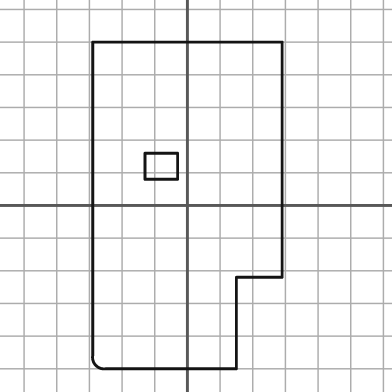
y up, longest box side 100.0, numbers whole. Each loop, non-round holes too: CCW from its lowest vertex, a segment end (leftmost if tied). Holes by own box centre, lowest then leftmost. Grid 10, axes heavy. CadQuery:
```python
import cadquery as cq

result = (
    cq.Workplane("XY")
    .moveTo(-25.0, -50.0)
    .lineTo(15.0, -50.0)
    .lineTo(15.0, -22.0)
    .lineTo(29.0, -22.0)
    .lineTo(29.0, 50.0)
    .lineTo(-29.0, 50.0)
    .lineTo(-29.0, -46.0)
    .threePointArc((-28.0, -49.0), (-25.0, -50.0))
    .close()
    .moveTo(-13.0, 8.0)
    .lineTo(-3.0, 8.0)
    .lineTo(-3.0, 16.0)
    .lineTo(-13.0, 16.0)
    .close()
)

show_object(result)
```